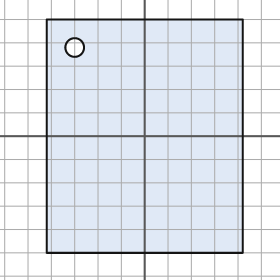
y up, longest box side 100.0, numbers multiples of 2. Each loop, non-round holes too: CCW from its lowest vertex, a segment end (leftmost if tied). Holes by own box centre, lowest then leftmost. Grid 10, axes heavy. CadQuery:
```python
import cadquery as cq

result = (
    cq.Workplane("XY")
    .moveTo(-42.0, -50.0)
    .lineTo(42.0, -50.0)
    .lineTo(42.0, 50.0)
    .lineTo(-42.0, 50.0)
    .close()
    .moveTo(-30.0, 38.0)
    .circle(4.0)
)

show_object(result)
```